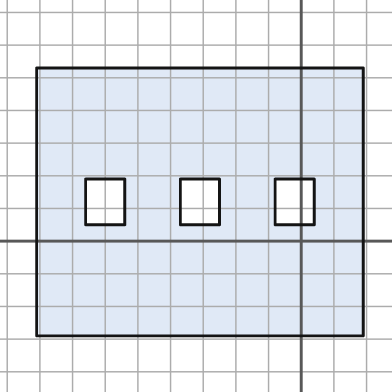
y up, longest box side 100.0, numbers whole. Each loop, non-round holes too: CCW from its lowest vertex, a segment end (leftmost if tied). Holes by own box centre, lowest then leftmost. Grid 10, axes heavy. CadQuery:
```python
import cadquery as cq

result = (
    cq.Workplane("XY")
    .moveTo(-81.0, -29.0)
    .lineTo(19.0, -29.0)
    .lineTo(19.0, 53.0)
    .lineTo(-81.0, 53.0)
    .close()
    .moveTo(-66.0, 5.0)
    .lineTo(-54.0, 5.0)
    .lineTo(-54.0, 19.0)
    .lineTo(-66.0, 19.0)
    .close()
    .moveTo(-37.0, 5.0)
    .lineTo(-25.0, 5.0)
    .lineTo(-25.0, 19.0)
    .lineTo(-37.0, 19.0)
    .close()
    .moveTo(-8.0, 5.0)
    .lineTo(4.0, 5.0)
    .lineTo(4.0, 19.0)
    .lineTo(-8.0, 19.0)
    .close()
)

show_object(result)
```